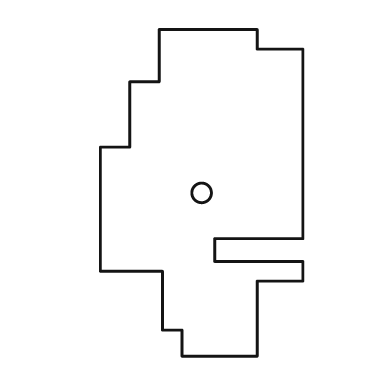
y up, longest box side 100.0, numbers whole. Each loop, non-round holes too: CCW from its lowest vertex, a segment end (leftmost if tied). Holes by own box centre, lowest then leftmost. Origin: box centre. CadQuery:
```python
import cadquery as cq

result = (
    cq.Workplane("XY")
    .moveTo(-6.0, -50.0)
    .lineTo(17.0, -50.0)
    .lineTo(17.0, -27.0)
    .lineTo(31.0, -27.0)
    .lineTo(31.0, -21.0)
    .lineTo(4.0, -21.0)
    .lineTo(4.0, -14.0)
    .lineTo(31.0, -14.0)
    .lineTo(31.0, 44.0)
    .lineTo(17.0, 44.0)
    .lineTo(17.0, 50.0)
    .lineTo(-13.0, 50.0)
    .lineTo(-13.0, 34.0)
    .lineTo(-22.0, 34.0)
    .lineTo(-22.0, 14.0)
    .lineTo(-31.0, 14.0)
    .lineTo(-31.0, -24.0)
    .lineTo(-12.0, -24.0)
    .lineTo(-12.0, -42.0)
    .lineTo(-6.0, -42.0)
    .close()
    .moveTo(0.0, 0.0)
    .circle(3.0)
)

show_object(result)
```